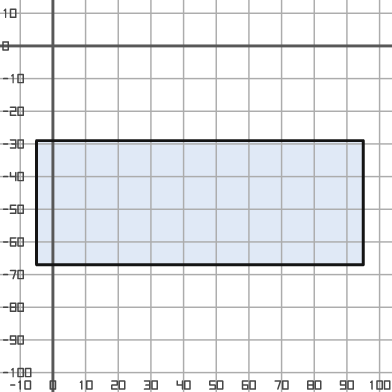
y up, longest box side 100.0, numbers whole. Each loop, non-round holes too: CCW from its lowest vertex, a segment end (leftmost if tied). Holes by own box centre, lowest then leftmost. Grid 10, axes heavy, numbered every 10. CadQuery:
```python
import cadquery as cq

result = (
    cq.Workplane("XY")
    .moveTo(-5.0, -67.0)
    .lineTo(95.0, -67.0)
    .lineTo(95.0, -29.0)
    .lineTo(-5.0, -29.0)
    .close()
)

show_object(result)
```